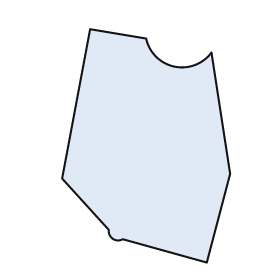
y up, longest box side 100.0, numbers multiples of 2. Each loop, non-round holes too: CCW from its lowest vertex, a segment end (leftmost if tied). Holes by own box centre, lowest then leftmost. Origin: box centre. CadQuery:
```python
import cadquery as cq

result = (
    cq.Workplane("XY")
    .moveTo(26.0, -50.0)
    .lineTo(36.0, -12.0)
    .lineTo(28.0, 40.0)
    .threePointArc((12.0, 34.0), (0.0, 46.0))
    .lineTo(-24.0, 50.0)
    .lineTo(-36.0, -14.0)
    .lineTo(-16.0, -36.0)
    .threePointArc((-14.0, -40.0), (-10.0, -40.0))
    .close()
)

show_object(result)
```